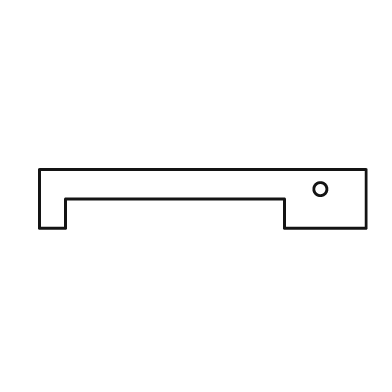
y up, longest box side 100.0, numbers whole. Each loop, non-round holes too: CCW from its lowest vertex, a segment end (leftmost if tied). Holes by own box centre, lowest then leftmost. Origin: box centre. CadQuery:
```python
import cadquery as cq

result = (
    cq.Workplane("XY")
    .moveTo(-50.0, -9.0)
    .lineTo(-42.0, -9.0)
    .lineTo(-42.0, 0.0)
    .lineTo(25.0, 0.0)
    .lineTo(25.0, -9.0)
    .lineTo(50.0, -9.0)
    .lineTo(50.0, 9.0)
    .lineTo(-50.0, 9.0)
    .close()
    .moveTo(36.0, 3.0)
    .circle(2.0)
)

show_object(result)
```